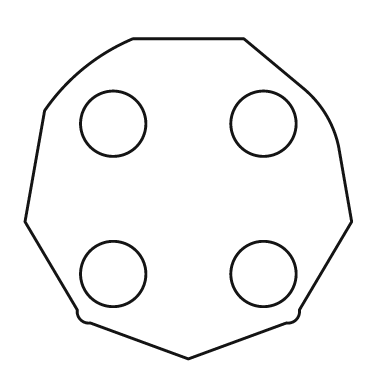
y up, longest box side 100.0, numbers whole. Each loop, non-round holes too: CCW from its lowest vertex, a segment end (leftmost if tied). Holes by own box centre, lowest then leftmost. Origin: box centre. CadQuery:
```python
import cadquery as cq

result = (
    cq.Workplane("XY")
    .moveTo(0.0, -49.0)
    .lineTo(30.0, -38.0)
    .threePointArc((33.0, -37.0), (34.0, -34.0))
    .lineTo(50.0, -7.0)
    .lineTo(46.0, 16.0)
    .threePointArc((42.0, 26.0), (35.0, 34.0))
    .lineTo(17.0, 49.0)
    .lineTo(-17.0, 49.0)
    .threePointArc((-32.0, 40.0), (-44.0, 27.0))
    .lineTo(-50.0, -7.0)
    .lineTo(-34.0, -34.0)
    .threePointArc((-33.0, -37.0), (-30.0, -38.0))
    .close()
    .moveTo(-23.0, -23.0)
    .circle(10.0)
    .moveTo(23.0, -23.0)
    .circle(10.0)
    .moveTo(-23.0, 23.0)
    .circle(10.0)
    .moveTo(23.0, 23.0)
    .circle(10.0)
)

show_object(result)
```